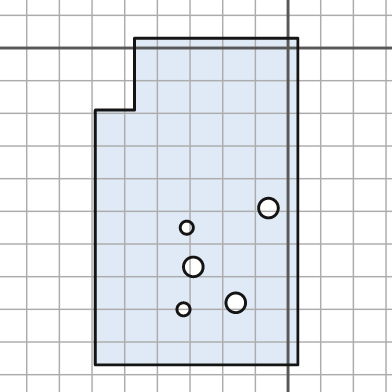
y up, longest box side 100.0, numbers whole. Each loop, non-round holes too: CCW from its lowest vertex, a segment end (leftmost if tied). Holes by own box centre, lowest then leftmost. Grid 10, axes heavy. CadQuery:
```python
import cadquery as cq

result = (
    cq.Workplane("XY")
    .moveTo(-59.0, -97.0)
    .lineTo(3.0, -97.0)
    .lineTo(3.0, 3.0)
    .lineTo(-47.0, 3.0)
    .lineTo(-47.0, -19.0)
    .lineTo(-59.0, -19.0)
    .close()
    .moveTo(-32.0, -80.0)
    .circle(2.0)
    .moveTo(-16.0, -78.0)
    .circle(3.0)
    .moveTo(-29.0, -67.0)
    .circle(3.0)
    .moveTo(-31.0, -55.0)
    .circle(2.0)
    .moveTo(-6.0, -49.0)
    .circle(3.0)
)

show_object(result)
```